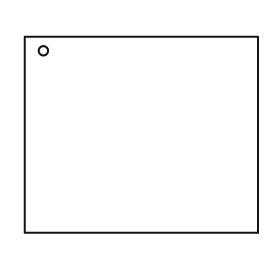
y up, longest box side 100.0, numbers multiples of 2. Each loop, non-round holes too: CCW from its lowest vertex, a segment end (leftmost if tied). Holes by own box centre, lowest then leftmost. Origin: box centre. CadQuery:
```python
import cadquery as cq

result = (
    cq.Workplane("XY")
    .moveTo(-50.0, -42.0)
    .lineTo(50.0, -42.0)
    .lineTo(50.0, 42.0)
    .lineTo(-50.0, 42.0)
    .close()
    .moveTo(-42.0, 36.0)
    .circle(2.0)
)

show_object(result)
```